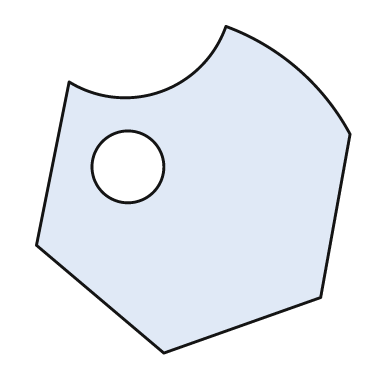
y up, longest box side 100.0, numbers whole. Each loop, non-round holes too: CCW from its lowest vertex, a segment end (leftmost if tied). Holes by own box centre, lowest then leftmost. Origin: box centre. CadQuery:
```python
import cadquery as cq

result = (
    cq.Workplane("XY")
    .moveTo(-9.0, -50.0)
    .lineTo(39.0, -33.0)
    .lineTo(48.0, 17.0)
    .threePointArc((32.0, 37.0), (10.0, 50.0))
    .threePointArc((-10.0, 30.0), (-38.0, 33.0))
    .lineTo(-48.0, -17.0)
    .close()
    .moveTo(-20.0, 7.0)
    .circle(11.0)
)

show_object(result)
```